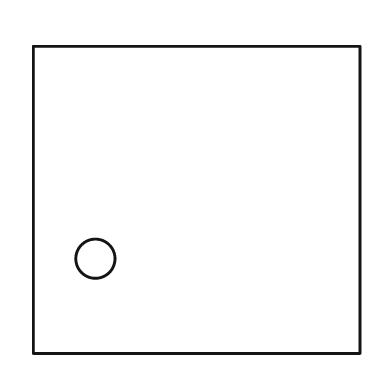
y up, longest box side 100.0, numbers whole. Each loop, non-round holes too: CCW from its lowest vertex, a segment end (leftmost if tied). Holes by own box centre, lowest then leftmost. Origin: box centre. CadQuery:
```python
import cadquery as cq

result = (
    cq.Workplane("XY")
    .moveTo(-50.0, -47.0)
    .lineTo(50.0, -47.0)
    .lineTo(50.0, 47.0)
    .lineTo(-50.0, 47.0)
    .close()
    .moveTo(-31.0, -18.0)
    .circle(6.0)
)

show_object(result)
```